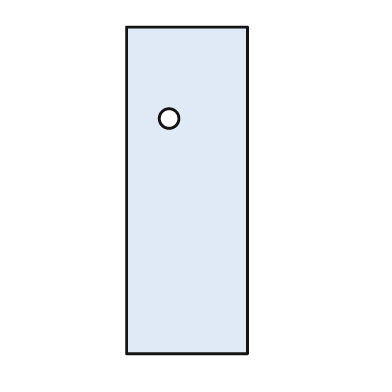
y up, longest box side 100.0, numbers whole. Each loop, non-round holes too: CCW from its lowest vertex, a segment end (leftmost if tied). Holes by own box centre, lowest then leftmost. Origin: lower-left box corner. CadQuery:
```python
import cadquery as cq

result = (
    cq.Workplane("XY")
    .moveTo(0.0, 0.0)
    .lineTo(37.0, 0.0)
    .lineTo(37.0, 100.0)
    .lineTo(0.0, 100.0)
    .close()
    .moveTo(13.0, 72.0)
    .circle(3.0)
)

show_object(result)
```